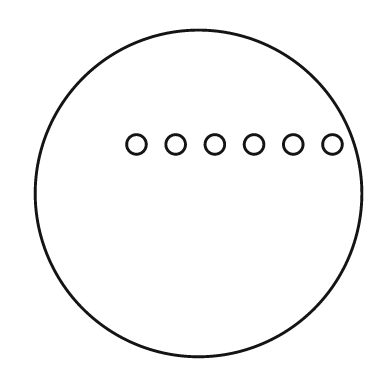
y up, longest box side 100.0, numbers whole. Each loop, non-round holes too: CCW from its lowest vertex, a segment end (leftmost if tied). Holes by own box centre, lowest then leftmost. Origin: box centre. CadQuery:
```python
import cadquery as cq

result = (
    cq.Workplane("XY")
    .moveTo(0.0, 0.0)
    .circle(50.0)
    .moveTo(-19.0, 15.0)
    .circle(3.0)
    .moveTo(-7.0, 15.0)
    .circle(3.0)
    .moveTo(5.0, 15.0)
    .circle(3.0)
    .moveTo(17.0, 15.0)
    .circle(3.0)
    .moveTo(29.0, 15.0)
    .circle(3.0)
    .moveTo(41.0, 15.0)
    .circle(3.0)
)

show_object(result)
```